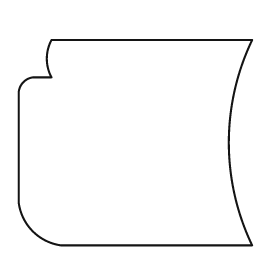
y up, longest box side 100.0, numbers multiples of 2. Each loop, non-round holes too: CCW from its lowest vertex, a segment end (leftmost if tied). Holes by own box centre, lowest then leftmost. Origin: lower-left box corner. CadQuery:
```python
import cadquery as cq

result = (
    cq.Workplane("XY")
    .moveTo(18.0, 0.0)
    .lineTo(100.0, 0.0)
    .threePointArc((90.0, 44.0), (100.0, 88.0))
    .lineTo(14.0, 88.0)
    .threePointArc((12.0, 80.0), (14.0, 72.0))
    .lineTo(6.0, 72.0)
    .threePointArc((2.0, 70.0), (0.0, 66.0))
    .lineTo(0.0, 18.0)
    .threePointArc((6.0, 6.0), (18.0, 0.0))
    .close()
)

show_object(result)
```